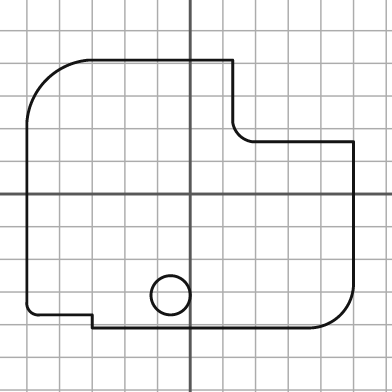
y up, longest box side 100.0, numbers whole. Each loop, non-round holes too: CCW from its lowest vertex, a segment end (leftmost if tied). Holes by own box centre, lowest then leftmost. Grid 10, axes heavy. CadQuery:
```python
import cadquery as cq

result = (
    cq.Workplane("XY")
    .moveTo(-30.0, -41.0)
    .lineTo(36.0, -41.0)
    .threePointArc((46.0, -37.0), (50.0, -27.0))
    .lineTo(50.0, 16.0)
    .lineTo(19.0, 16.0)
    .threePointArc((15.0, 18.0), (13.0, 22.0))
    .lineTo(13.0, 41.0)
    .lineTo(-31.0, 41.0)
    .threePointArc((-44.0, 35.0), (-50.0, 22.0))
    .lineTo(-50.0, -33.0)
    .threePointArc((-49.0, -36.0), (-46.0, -37.0))
    .lineTo(-30.0, -37.0)
    .close()
    .moveTo(-6.0, -31.0)
    .circle(6.0)
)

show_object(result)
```